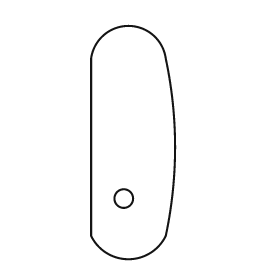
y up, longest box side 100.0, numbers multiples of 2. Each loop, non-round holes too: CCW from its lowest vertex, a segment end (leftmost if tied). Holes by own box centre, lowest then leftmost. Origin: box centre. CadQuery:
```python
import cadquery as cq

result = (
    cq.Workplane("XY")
    .moveTo(-18.0, -40.0)
    .threePointArc((-2.0, -50.0), (14.0, -40.0))
    .threePointArc((18.0, -2.0), (14.0, 36.0))
    .threePointArc((-2.0, 50.0), (-18.0, 36.0))
    .close()
    .moveTo(-4.0, -24.0)
    .circle(4.0)
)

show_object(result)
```